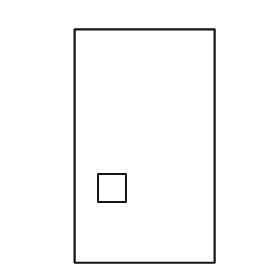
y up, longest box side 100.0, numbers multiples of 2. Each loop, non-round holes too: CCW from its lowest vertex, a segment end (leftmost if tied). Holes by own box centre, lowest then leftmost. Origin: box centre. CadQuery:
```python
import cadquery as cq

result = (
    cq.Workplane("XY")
    .moveTo(-30.0, -50.0)
    .lineTo(30.0, -50.0)
    .lineTo(30.0, 50.0)
    .lineTo(-30.0, 50.0)
    .close()
    .moveTo(-20.0, -24.0)
    .lineTo(-8.0, -24.0)
    .lineTo(-8.0, -12.0)
    .lineTo(-20.0, -12.0)
    .close()
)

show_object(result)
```